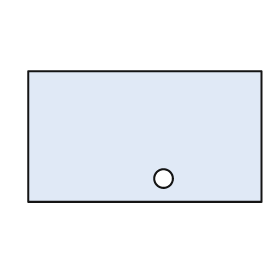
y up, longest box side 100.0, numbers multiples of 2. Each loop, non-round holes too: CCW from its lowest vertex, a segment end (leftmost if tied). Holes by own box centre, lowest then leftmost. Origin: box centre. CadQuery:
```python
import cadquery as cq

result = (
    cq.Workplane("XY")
    .moveTo(-50.0, -28.0)
    .lineTo(50.0, -28.0)
    .lineTo(50.0, 28.0)
    .lineTo(-50.0, 28.0)
    .close()
    .moveTo(8.0, -18.0)
    .circle(4.0)
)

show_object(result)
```